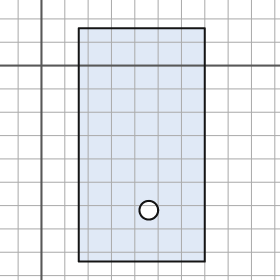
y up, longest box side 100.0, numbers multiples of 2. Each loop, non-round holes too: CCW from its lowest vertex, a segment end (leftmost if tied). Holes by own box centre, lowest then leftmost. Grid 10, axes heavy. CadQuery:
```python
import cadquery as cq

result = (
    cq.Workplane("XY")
    .moveTo(16.0, -84.0)
    .lineTo(70.0, -84.0)
    .lineTo(70.0, 16.0)
    .lineTo(16.0, 16.0)
    .close()
    .moveTo(46.0, -62.0)
    .circle(4.0)
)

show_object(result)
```